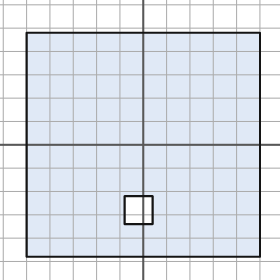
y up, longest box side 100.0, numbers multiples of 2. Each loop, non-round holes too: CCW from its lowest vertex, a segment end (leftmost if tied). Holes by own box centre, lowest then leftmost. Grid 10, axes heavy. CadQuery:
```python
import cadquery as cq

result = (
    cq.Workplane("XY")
    .moveTo(-50.0, -48.0)
    .lineTo(50.0, -48.0)
    .lineTo(50.0, 48.0)
    .lineTo(-50.0, 48.0)
    .close()
    .moveTo(-8.0, -34.0)
    .lineTo(4.0, -34.0)
    .lineTo(4.0, -22.0)
    .lineTo(-8.0, -22.0)
    .close()
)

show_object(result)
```